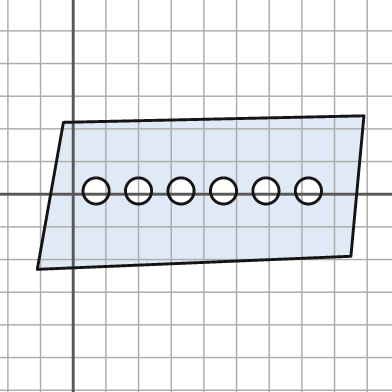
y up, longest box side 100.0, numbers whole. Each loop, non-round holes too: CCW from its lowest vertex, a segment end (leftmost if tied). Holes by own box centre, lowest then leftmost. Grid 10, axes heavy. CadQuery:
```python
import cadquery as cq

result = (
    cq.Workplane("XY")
    .moveTo(-11.0, -23.0)
    .lineTo(85.0, -19.0)
    .lineTo(89.0, 24.0)
    .lineTo(-3.0, 22.0)
    .close()
    .moveTo(7.0, 1.0)
    .circle(4.0)
    .moveTo(20.0, 1.0)
    .circle(4.0)
    .moveTo(33.0, 1.0)
    .circle(4.0)
    .moveTo(46.0, 1.0)
    .circle(4.0)
    .moveTo(59.0, 1.0)
    .circle(4.0)
    .moveTo(72.0, 1.0)
    .circle(4.0)
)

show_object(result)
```